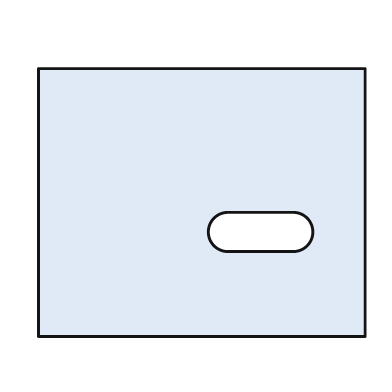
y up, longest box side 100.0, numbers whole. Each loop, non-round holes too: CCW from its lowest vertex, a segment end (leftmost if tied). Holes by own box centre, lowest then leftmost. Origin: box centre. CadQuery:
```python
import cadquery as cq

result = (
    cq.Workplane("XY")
    .moveTo(-50.0, -41.0)
    .lineTo(50.0, -41.0)
    .lineTo(50.0, 41.0)
    .lineTo(-50.0, 41.0)
    .close()
    .moveTo(8.0, -15.0)
    .lineTo(28.0, -15.0)
    .threePointArc((34.0, -9.0), (28.0, -3.0))
    .lineTo(8.0, -3.0)
    .threePointArc((2.0, -9.0), (8.0, -15.0))
    .close()
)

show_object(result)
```